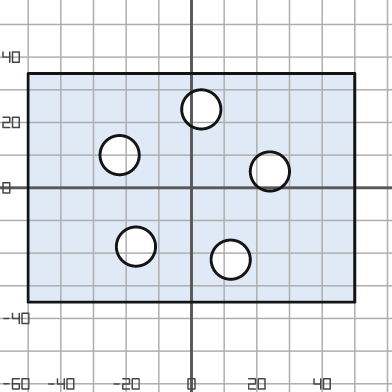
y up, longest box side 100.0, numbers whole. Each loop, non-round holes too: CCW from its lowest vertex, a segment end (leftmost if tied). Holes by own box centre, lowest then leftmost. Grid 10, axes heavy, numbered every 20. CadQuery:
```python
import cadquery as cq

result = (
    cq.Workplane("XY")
    .moveTo(-50.0, -35.0)
    .lineTo(50.0, -35.0)
    .lineTo(50.0, 35.0)
    .lineTo(-50.0, 35.0)
    .close()
    .moveTo(12.0, -22.0)
    .circle(6.0)
    .moveTo(-17.0, -18.0)
    .circle(6.0)
    .moveTo(24.0, 5.0)
    .circle(6.0)
    .moveTo(-22.0, 10.0)
    .circle(6.0)
    .moveTo(3.0, 24.0)
    .circle(6.0)
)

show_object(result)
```